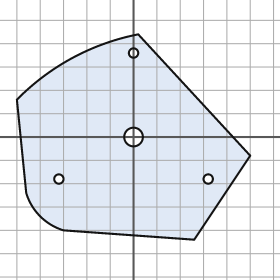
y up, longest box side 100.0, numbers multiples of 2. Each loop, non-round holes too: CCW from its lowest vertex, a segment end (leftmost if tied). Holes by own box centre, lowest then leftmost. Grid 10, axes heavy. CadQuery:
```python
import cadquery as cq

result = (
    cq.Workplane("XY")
    .moveTo(26.0, -44.0)
    .lineTo(50.0, -8.0)
    .lineTo(2.0, 44.0)
    .threePointArc((-26.0, 34.0), (-50.0, 16.0))
    .lineTo(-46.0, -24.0)
    .threePointArc((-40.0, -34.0), (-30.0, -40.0))
    .close()
    .moveTo(-32.0, -18.0)
    .circle(2.0)
    .moveTo(32.0, -18.0)
    .circle(2.0)
    .moveTo(0.0, 0.0)
    .circle(4.0)
    .moveTo(0.0, 36.0)
    .circle(2.0)
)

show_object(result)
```